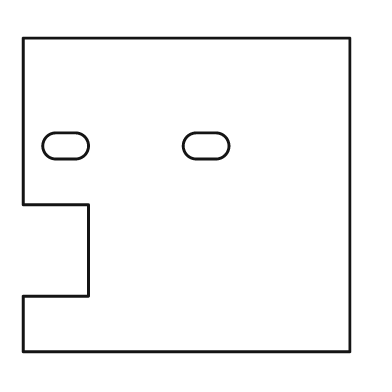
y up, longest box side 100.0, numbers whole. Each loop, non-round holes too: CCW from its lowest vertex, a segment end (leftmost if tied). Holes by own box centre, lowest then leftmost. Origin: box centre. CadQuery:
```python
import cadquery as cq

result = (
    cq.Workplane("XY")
    .moveTo(-50.0, -48.0)
    .lineTo(50.0, -48.0)
    .lineTo(50.0, 48.0)
    .lineTo(-50.0, 48.0)
    .lineTo(-50.0, -3.0)
    .lineTo(-30.0, -3.0)
    .lineTo(-30.0, -31.0)
    .lineTo(-50.0, -31.0)
    .close()
    .moveTo(-40.0, 11.0)
    .lineTo(-34.0, 11.0)
    .threePointArc((-30.0, 15.0), (-34.0, 19.0))
    .lineTo(-40.0, 19.0)
    .threePointArc((-44.0, 15.0), (-40.0, 11.0))
    .close()
    .moveTo(3.0, 11.0)
    .lineTo(9.0, 11.0)
    .threePointArc((13.0, 15.0), (9.0, 19.0))
    .lineTo(3.0, 19.0)
    .threePointArc((-1.0, 15.0), (3.0, 11.0))
    .close()
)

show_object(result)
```